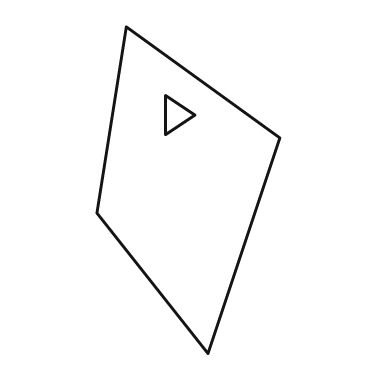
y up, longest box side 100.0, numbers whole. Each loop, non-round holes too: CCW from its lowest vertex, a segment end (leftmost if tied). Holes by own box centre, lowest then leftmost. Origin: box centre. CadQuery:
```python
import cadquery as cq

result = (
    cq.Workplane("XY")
    .moveTo(6.0, -50.0)
    .lineTo(28.0, 16.0)
    .lineTo(-19.0, 50.0)
    .lineTo(-28.0, -7.0)
    .close()
    .moveTo(-7.0, 17.0)
    .lineTo(2.0, 23.0)
    .lineTo(-7.0, 29.0)
    .close()
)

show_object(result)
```